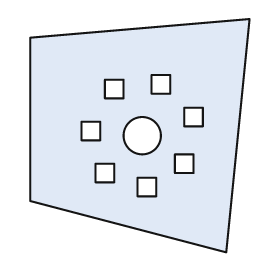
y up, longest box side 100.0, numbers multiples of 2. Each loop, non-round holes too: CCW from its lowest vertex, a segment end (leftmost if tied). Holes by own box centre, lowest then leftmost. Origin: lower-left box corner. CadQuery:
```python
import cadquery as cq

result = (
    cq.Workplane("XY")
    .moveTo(84.0, 0.0)
    .lineTo(94.0, 100.0)
    .lineTo(0.0, 92.0)
    .lineTo(0.0, 22.0)
    .close()
    .moveTo(46.0, 24.0)
    .lineTo(54.0, 24.0)
    .lineTo(54.0, 32.0)
    .lineTo(46.0, 32.0)
    .close()
    .moveTo(28.0, 30.0)
    .lineTo(36.0, 30.0)
    .lineTo(36.0, 38.0)
    .lineTo(28.0, 38.0)
    .close()
    .moveTo(62.0, 34.0)
    .lineTo(70.0, 34.0)
    .lineTo(70.0, 42.0)
    .lineTo(62.0, 42.0)
    .close()
    .moveTo(48.0, 50.0)
    .circle(8.0)
    .moveTo(22.0, 48.0)
    .lineTo(30.0, 48.0)
    .lineTo(30.0, 56.0)
    .lineTo(22.0, 56.0)
    .close()
    .moveTo(66.0, 54.0)
    .lineTo(74.0, 54.0)
    .lineTo(74.0, 62.0)
    .lineTo(66.0, 62.0)
    .close()
    .moveTo(32.0, 66.0)
    .lineTo(40.0, 66.0)
    .lineTo(40.0, 74.0)
    .lineTo(32.0, 74.0)
    .close()
    .moveTo(52.0, 68.0)
    .lineTo(60.0, 68.0)
    .lineTo(60.0, 76.0)
    .lineTo(52.0, 76.0)
    .close()
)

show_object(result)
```